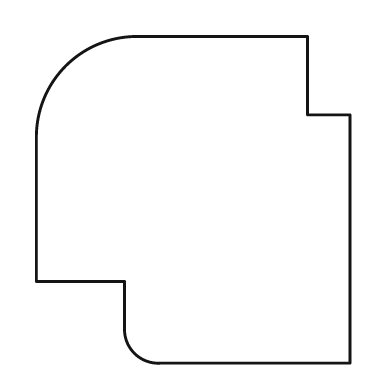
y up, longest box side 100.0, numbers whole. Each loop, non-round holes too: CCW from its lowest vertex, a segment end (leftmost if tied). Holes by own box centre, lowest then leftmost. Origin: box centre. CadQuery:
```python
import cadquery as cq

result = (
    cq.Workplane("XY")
    .moveTo(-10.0, -50.0)
    .lineTo(48.0, -50.0)
    .lineTo(48.0, 26.0)
    .lineTo(35.0, 26.0)
    .lineTo(35.0, 50.0)
    .lineTo(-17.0, 50.0)
    .threePointArc((-39.0, 41.0), (-48.0, 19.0))
    .lineTo(-48.0, -25.0)
    .lineTo(-21.0, -25.0)
    .lineTo(-21.0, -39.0)
    .threePointArc((-18.0, -47.0), (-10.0, -50.0))
    .close()
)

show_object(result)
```